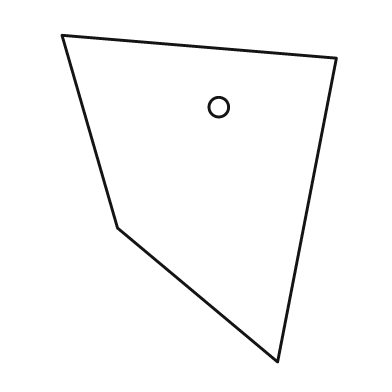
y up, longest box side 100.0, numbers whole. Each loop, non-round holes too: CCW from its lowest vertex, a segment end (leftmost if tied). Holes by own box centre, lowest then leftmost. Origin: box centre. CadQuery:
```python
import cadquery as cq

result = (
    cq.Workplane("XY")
    .moveTo(24.0, -50.0)
    .lineTo(42.0, 43.0)
    .lineTo(-42.0, 50.0)
    .lineTo(-25.0, -9.0)
    .close()
    .moveTo(6.0, 28.0)
    .circle(3.0)
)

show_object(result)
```